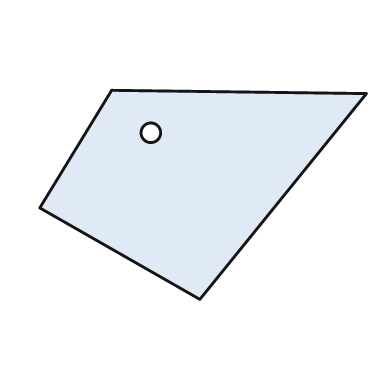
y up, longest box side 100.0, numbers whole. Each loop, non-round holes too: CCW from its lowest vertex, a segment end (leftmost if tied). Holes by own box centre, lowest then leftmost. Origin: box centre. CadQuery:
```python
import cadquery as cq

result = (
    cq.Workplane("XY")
    .moveTo(-1.0, -32.0)
    .lineTo(50.0, 31.0)
    .lineTo(-28.0, 32.0)
    .lineTo(-50.0, -4.0)
    .close()
    .moveTo(-16.0, 19.0)
    .circle(3.0)
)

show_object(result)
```